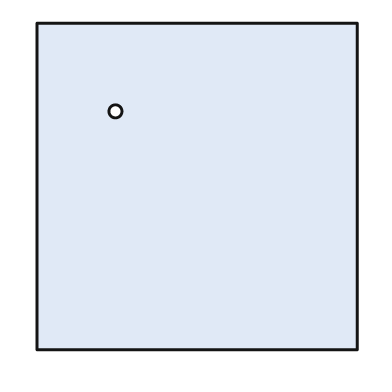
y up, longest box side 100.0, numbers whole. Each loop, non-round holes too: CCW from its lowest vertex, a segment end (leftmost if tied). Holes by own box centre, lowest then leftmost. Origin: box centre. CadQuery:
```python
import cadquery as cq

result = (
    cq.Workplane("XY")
    .moveTo(-49.0, -50.0)
    .lineTo(49.0, -50.0)
    .lineTo(49.0, 50.0)
    .lineTo(-49.0, 50.0)
    .close()
    .moveTo(-25.0, 23.0)
    .circle(2.0)
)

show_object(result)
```